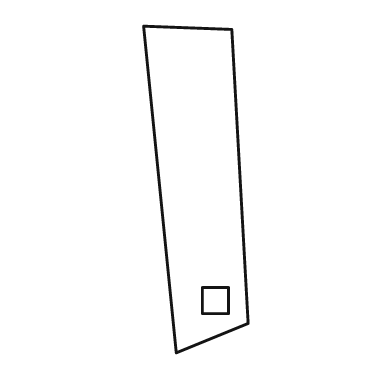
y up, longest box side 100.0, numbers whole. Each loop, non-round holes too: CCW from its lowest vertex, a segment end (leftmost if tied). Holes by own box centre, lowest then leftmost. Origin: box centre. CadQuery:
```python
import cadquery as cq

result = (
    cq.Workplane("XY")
    .moveTo(-6.0, -50.0)
    .lineTo(16.0, -41.0)
    .lineTo(11.0, 49.0)
    .lineTo(-16.0, 50.0)
    .close()
    .moveTo(2.0, -38.0)
    .lineTo(10.0, -38.0)
    .lineTo(10.0, -30.0)
    .lineTo(2.0, -30.0)
    .close()
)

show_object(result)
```